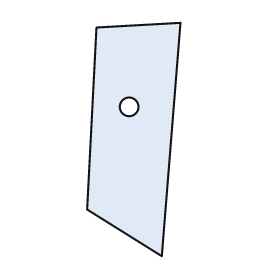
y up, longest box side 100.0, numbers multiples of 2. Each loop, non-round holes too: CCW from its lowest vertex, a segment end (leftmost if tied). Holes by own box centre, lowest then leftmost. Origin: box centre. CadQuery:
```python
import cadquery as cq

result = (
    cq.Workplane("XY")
    .moveTo(12.0, -50.0)
    .lineTo(20.0, 50.0)
    .lineTo(-16.0, 48.0)
    .lineTo(-20.0, -30.0)
    .close()
    .moveTo(-2.0, 14.0)
    .circle(4.0)
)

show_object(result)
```